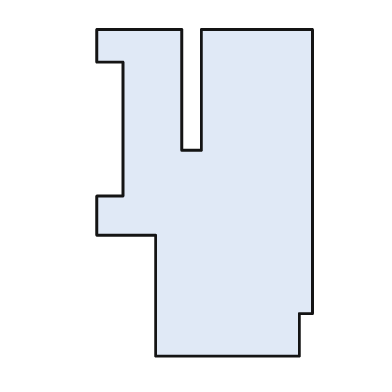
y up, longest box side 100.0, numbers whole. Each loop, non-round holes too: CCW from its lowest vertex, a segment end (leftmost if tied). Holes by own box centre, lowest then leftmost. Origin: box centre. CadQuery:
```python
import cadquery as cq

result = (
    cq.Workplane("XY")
    .moveTo(-15.0, -50.0)
    .lineTo(29.0, -50.0)
    .lineTo(29.0, -37.0)
    .lineTo(33.0, -37.0)
    .lineTo(33.0, 50.0)
    .lineTo(-1.0, 50.0)
    .lineTo(-1.0, 13.0)
    .lineTo(-7.0, 13.0)
    .lineTo(-7.0, 50.0)
    .lineTo(-33.0, 50.0)
    .lineTo(-33.0, 40.0)
    .lineTo(-25.0, 40.0)
    .lineTo(-25.0, -1.0)
    .lineTo(-33.0, -1.0)
    .lineTo(-33.0, -13.0)
    .lineTo(-15.0, -13.0)
    .close()
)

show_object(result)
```